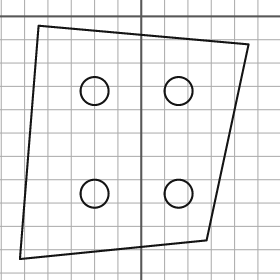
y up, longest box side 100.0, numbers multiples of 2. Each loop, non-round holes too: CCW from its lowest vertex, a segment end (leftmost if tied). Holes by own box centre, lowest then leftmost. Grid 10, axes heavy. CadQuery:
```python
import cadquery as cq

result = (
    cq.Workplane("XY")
    .moveTo(-52.0, -104.0)
    .lineTo(28.0, -96.0)
    .lineTo(46.0, -12.0)
    .lineTo(-44.0, -4.0)
    .close()
    .moveTo(-20.0, -76.0)
    .circle(6.0)
    .moveTo(16.0, -76.0)
    .circle(6.0)
    .moveTo(-20.0, -32.0)
    .circle(6.0)
    .moveTo(16.0, -32.0)
    .circle(6.0)
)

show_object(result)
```